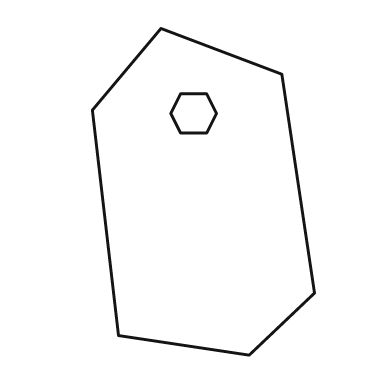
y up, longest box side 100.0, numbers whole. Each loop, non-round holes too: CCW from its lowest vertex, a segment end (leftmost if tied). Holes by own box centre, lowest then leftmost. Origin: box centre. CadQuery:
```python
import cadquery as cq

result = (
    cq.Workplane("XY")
    .moveTo(14.0, -50.0)
    .lineTo(34.0, -31.0)
    .lineTo(24.0, 36.0)
    .lineTo(-13.0, 50.0)
    .lineTo(-34.0, 25.0)
    .lineTo(-26.0, -44.0)
    .close()
    .moveTo(-7.0, 18.0)
    .lineTo(1.0, 18.0)
    .lineTo(4.0, 24.0)
    .lineTo(1.0, 30.0)
    .lineTo(-7.0, 30.0)
    .lineTo(-10.0, 24.0)
    .close()
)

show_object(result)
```